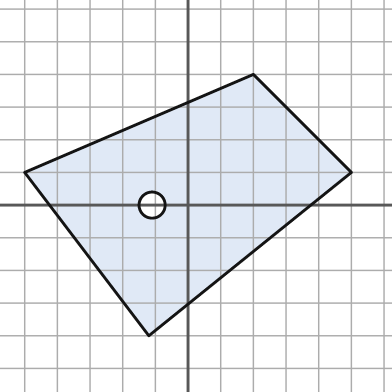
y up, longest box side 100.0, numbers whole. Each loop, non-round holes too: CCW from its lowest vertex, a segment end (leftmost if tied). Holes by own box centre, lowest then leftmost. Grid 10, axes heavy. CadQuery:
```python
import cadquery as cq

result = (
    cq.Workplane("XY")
    .moveTo(-12.0, -40.0)
    .lineTo(50.0, 10.0)
    .lineTo(20.0, 40.0)
    .lineTo(-50.0, 10.0)
    .close()
    .moveTo(-11.0, 0.0)
    .circle(4.0)
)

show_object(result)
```